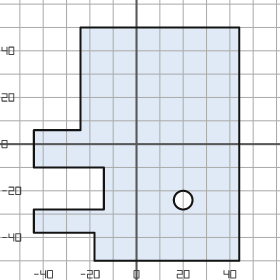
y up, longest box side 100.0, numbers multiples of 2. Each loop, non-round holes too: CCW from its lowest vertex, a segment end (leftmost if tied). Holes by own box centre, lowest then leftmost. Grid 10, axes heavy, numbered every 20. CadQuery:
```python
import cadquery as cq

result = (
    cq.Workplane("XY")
    .moveTo(-18.0, -50.0)
    .lineTo(44.0, -50.0)
    .lineTo(44.0, 50.0)
    .lineTo(-24.0, 50.0)
    .lineTo(-24.0, 6.0)
    .lineTo(-44.0, 6.0)
    .lineTo(-44.0, -10.0)
    .lineTo(-14.0, -10.0)
    .lineTo(-14.0, -28.0)
    .lineTo(-44.0, -28.0)
    .lineTo(-44.0, -38.0)
    .lineTo(-18.0, -38.0)
    .close()
    .moveTo(20.0, -24.0)
    .circle(4.0)
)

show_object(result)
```